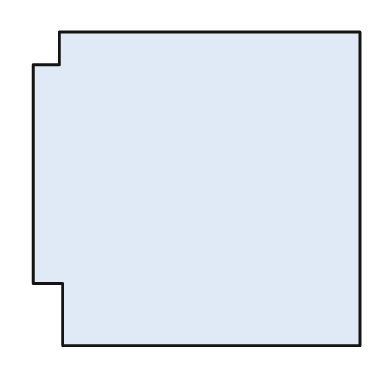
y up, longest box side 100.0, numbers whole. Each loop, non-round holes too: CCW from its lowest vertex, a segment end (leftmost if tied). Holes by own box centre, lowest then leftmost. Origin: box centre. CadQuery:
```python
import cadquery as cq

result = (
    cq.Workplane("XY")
    .moveTo(-41.0, -48.0)
    .lineTo(50.0, -48.0)
    .lineTo(50.0, 48.0)
    .lineTo(-42.0, 48.0)
    .lineTo(-42.0, 38.0)
    .lineTo(-50.0, 38.0)
    .lineTo(-50.0, -29.0)
    .lineTo(-41.0, -29.0)
    .close()
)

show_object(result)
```